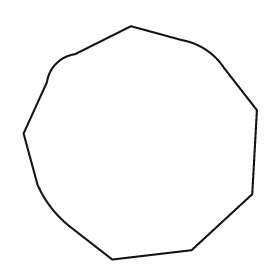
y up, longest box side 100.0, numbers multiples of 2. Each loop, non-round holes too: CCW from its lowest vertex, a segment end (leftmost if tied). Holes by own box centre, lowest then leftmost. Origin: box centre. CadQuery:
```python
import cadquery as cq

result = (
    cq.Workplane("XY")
    .moveTo(-12.0, -50.0)
    .lineTo(22.0, -46.0)
    .lineTo(48.0, -22.0)
    .lineTo(50.0, 14.0)
    .lineTo(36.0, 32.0)
    .threePointArc((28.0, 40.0), (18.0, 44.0))
    .lineTo(-4.0, 50.0)
    .lineTo(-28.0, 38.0)
    .threePointArc((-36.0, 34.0), (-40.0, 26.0))
    .lineTo(-50.0, 4.0)
    .lineTo(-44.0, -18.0)
    .threePointArc((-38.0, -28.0), (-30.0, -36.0))
    .close()
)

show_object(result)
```